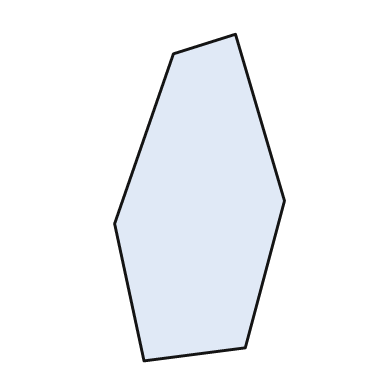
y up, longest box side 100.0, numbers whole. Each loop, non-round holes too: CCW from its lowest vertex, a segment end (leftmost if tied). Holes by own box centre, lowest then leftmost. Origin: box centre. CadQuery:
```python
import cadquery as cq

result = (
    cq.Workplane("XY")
    .moveTo(-17.0, -50.0)
    .lineTo(14.0, -46.0)
    .lineTo(26.0, -1.0)
    .lineTo(11.0, 50.0)
    .lineTo(-8.0, 44.0)
    .lineTo(-26.0, -8.0)
    .close()
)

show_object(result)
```